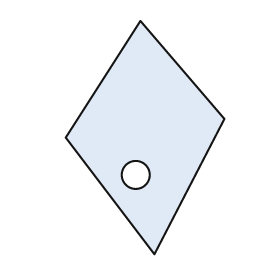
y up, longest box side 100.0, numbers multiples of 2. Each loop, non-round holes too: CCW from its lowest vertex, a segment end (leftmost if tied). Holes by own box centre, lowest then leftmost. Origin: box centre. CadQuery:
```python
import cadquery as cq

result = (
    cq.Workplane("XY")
    .moveTo(4.0, -50.0)
    .lineTo(34.0, 8.0)
    .lineTo(-2.0, 50.0)
    .lineTo(-34.0, 0.0)
    .close()
    .moveTo(-4.0, -16.0)
    .circle(6.0)
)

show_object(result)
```